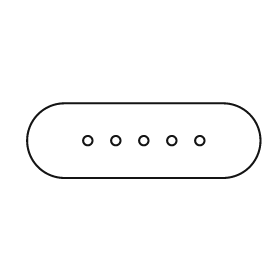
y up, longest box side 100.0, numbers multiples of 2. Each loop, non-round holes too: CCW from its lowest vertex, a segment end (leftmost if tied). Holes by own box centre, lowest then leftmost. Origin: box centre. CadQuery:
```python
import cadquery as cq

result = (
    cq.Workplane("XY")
    .moveTo(-34.0, -16.0)
    .lineTo(34.0, -16.0)
    .threePointArc((50.0, 0.0), (34.0, 16.0))
    .lineTo(-34.0, 16.0)
    .threePointArc((-50.0, 0.0), (-34.0, -16.0))
    .close()
    .moveTo(-24.0, 0.0)
    .circle(2.0)
    .moveTo(-12.0, 0.0)
    .circle(2.0)
    .moveTo(0.0, 0.0)
    .circle(2.0)
    .moveTo(12.0, 0.0)
    .circle(2.0)
    .moveTo(24.0, 0.0)
    .circle(2.0)
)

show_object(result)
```